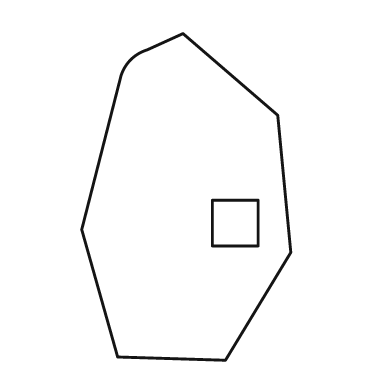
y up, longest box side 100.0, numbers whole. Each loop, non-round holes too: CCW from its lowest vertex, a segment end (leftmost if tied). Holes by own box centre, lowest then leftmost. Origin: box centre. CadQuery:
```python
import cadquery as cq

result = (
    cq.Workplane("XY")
    .moveTo(12.0, -50.0)
    .lineTo(32.0, -17.0)
    .lineTo(28.0, 25.0)
    .lineTo(-1.0, 50.0)
    .lineTo(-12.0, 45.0)
    .threePointArc((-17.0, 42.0), (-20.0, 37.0))
    .lineTo(-32.0, -10.0)
    .lineTo(-21.0, -49.0)
    .close()
    .moveTo(8.0, -15.0)
    .lineTo(22.0, -15.0)
    .lineTo(22.0, -1.0)
    .lineTo(8.0, -1.0)
    .close()
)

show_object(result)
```